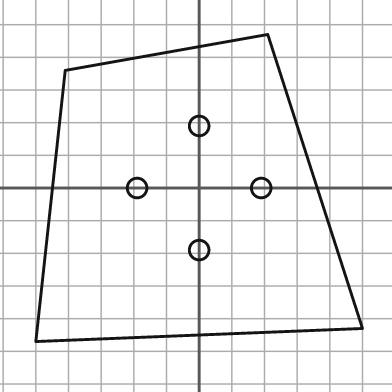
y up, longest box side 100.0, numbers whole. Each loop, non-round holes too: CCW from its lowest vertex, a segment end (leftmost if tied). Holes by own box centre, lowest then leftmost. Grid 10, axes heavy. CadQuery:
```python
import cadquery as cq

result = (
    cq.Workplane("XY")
    .moveTo(-50.0, -47.0)
    .lineTo(50.0, -43.0)
    .lineTo(21.0, 47.0)
    .lineTo(-41.0, 36.0)
    .close()
    .moveTo(0.0, -19.0)
    .circle(3.0)
    .moveTo(-19.0, 0.0)
    .circle(3.0)
    .moveTo(19.0, 0.0)
    .circle(3.0)
    .moveTo(0.0, 19.0)
    .circle(3.0)
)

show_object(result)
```